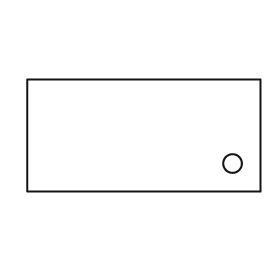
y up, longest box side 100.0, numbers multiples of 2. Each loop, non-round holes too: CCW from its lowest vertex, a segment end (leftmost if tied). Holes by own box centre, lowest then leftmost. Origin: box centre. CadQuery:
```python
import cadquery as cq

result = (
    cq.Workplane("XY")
    .moveTo(-50.0, -24.0)
    .lineTo(50.0, -24.0)
    .lineTo(50.0, 24.0)
    .lineTo(-50.0, 24.0)
    .close()
    .moveTo(38.0, -12.0)
    .circle(4.0)
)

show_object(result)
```